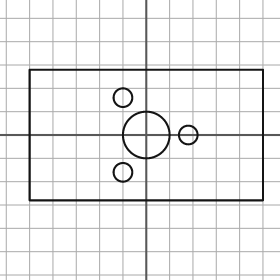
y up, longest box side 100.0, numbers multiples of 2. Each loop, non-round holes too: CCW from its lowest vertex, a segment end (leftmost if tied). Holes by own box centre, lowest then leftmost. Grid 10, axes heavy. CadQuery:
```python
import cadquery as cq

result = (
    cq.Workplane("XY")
    .moveTo(-50.0, -28.0)
    .lineTo(50.0, -28.0)
    .lineTo(50.0, 28.0)
    .lineTo(-50.0, 28.0)
    .close()
    .moveTo(-10.0, -16.0)
    .circle(4.0)
    .moveTo(0.0, 0.0)
    .circle(10.0)
    .moveTo(18.0, 0.0)
    .circle(4.0)
    .moveTo(-10.0, 16.0)
    .circle(4.0)
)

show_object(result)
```